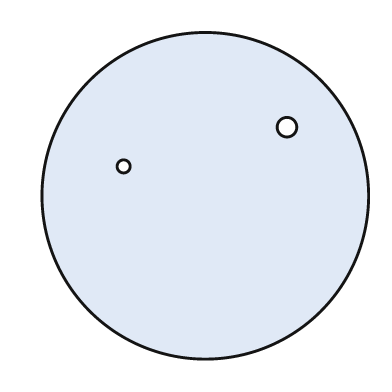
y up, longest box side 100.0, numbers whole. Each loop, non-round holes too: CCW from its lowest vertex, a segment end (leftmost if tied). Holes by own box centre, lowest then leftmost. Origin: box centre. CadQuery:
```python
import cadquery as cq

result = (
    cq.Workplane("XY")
    .moveTo(0.0, 0.0)
    .circle(50.0)
    .moveTo(-25.0, 9.0)
    .circle(2.0)
    .moveTo(25.0, 21.0)
    .circle(3.0)
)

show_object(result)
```